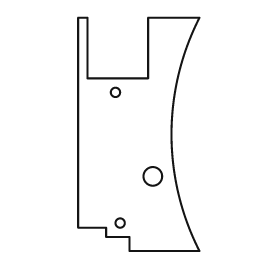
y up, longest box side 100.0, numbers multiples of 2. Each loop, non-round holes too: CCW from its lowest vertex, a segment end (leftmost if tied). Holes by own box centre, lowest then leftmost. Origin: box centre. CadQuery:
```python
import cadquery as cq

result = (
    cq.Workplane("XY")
    .moveTo(-4.0, -50.0)
    .lineTo(26.0, -50.0)
    .threePointArc((14.0, 0.0), (26.0, 50.0))
    .lineTo(4.0, 50.0)
    .lineTo(4.0, 24.0)
    .lineTo(-22.0, 24.0)
    .lineTo(-22.0, 50.0)
    .lineTo(-26.0, 50.0)
    .lineTo(-26.0, -40.0)
    .lineTo(-14.0, -40.0)
    .lineTo(-14.0, -44.0)
    .lineTo(-4.0, -44.0)
    .close()
    .moveTo(-8.0, -38.0)
    .circle(2.0)
    .moveTo(6.0, -18.0)
    .circle(4.0)
    .moveTo(-10.0, 18.0)
    .circle(2.0)
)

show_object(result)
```